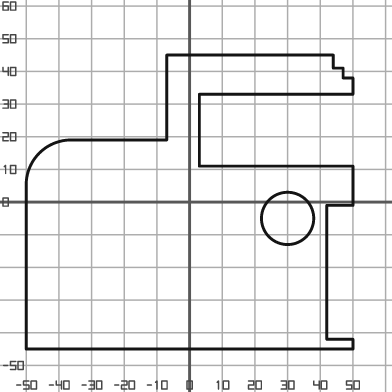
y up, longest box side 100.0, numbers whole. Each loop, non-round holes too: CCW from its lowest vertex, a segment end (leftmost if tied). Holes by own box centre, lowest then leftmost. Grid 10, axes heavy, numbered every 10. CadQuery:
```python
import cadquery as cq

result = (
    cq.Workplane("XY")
    .moveTo(-50.0, -45.0)
    .lineTo(50.0, -45.0)
    .lineTo(50.0, -42.0)
    .lineTo(42.0, -42.0)
    .lineTo(42.0, -1.0)
    .lineTo(50.0, -1.0)
    .lineTo(50.0, 11.0)
    .lineTo(3.0, 11.0)
    .lineTo(3.0, 33.0)
    .lineTo(50.0, 33.0)
    .lineTo(50.0, 38.0)
    .lineTo(47.0, 38.0)
    .lineTo(47.0, 41.0)
    .lineTo(44.0, 41.0)
    .lineTo(44.0, 45.0)
    .lineTo(-7.0, 45.0)
    .lineTo(-7.0, 19.0)
    .lineTo(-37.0, 19.0)
    .threePointArc((-46.0, 15.0), (-50.0, 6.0))
    .close()
    .moveTo(30.0, -5.0)
    .circle(8.0)
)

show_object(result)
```